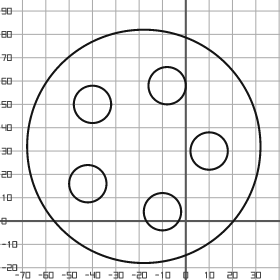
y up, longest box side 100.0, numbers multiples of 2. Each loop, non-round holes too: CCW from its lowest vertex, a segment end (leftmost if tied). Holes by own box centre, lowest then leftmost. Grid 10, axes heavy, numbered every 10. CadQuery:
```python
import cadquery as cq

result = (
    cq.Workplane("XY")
    .moveTo(-18.0, 32.0)
    .circle(50.0)
    .moveTo(-10.0, 4.0)
    .circle(8.0)
    .moveTo(-42.0, 16.0)
    .circle(8.0)
    .moveTo(10.0, 30.0)
    .circle(8.0)
    .moveTo(-40.0, 50.0)
    .circle(8.0)
    .moveTo(-8.0, 58.0)
    .circle(8.0)
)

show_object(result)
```